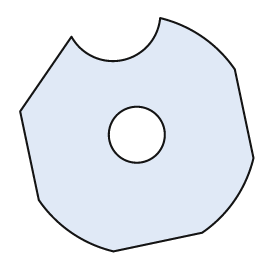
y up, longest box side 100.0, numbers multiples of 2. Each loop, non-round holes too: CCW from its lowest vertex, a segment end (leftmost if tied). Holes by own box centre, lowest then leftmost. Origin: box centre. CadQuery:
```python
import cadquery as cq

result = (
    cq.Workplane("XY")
    .moveTo(-10.0, -50.0)
    .lineTo(28.0, -42.0)
    .threePointArc((42.0, -28.0), (50.0, -10.0))
    .lineTo(42.0, 28.0)
    .threePointArc((28.0, 42.0), (10.0, 50.0))
    .threePointArc((-6.0, 32.0), (-28.0, 42.0))
    .lineTo(-50.0, 10.0)
    .lineTo(-42.0, -28.0)
    .threePointArc((-28.0, -42.0), (-10.0, -50.0))
    .close()
    .moveTo(0.0, 0.0)
    .circle(12.0)
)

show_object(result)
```